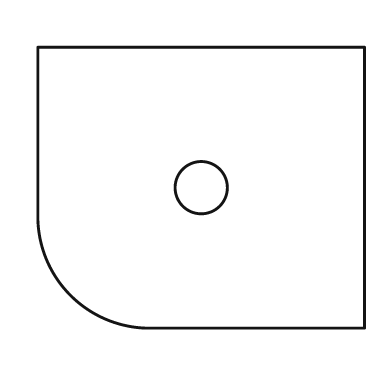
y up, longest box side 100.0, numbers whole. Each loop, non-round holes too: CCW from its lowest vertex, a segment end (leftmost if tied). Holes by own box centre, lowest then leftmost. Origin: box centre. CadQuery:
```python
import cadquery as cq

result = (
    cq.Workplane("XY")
    .moveTo(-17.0, -43.0)
    .lineTo(50.0, -43.0)
    .lineTo(50.0, 43.0)
    .lineTo(-50.0, 43.0)
    .lineTo(-50.0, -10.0)
    .threePointArc((-40.0, -33.0), (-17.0, -43.0))
    .close()
    .moveTo(0.0, 0.0)
    .circle(8.0)
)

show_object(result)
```